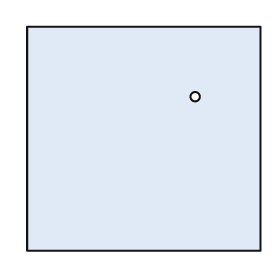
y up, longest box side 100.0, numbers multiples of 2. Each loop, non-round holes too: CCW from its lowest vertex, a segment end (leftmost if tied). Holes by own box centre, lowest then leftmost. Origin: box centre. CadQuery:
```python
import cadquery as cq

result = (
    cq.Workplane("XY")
    .moveTo(-50.0, -48.0)
    .lineTo(50.0, -48.0)
    .lineTo(50.0, 48.0)
    .lineTo(-50.0, 48.0)
    .close()
    .moveTo(22.0, 18.0)
    .circle(2.0)
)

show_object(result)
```